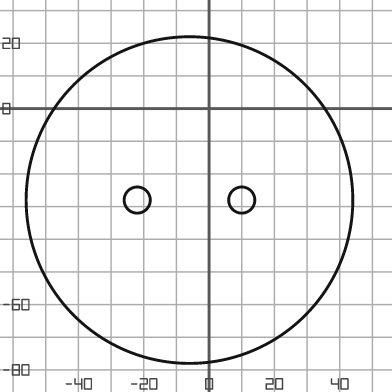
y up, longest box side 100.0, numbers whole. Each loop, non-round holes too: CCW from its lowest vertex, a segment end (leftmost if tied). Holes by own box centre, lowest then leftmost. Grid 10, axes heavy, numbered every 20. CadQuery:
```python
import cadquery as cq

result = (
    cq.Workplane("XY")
    .moveTo(-6.0, -28.0)
    .circle(50.0)
    .moveTo(-22.0, -28.0)
    .circle(4.0)
    .moveTo(10.0, -28.0)
    .circle(4.0)
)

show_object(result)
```